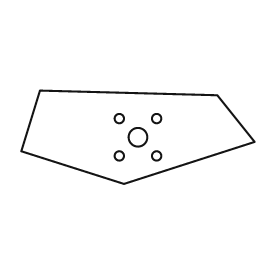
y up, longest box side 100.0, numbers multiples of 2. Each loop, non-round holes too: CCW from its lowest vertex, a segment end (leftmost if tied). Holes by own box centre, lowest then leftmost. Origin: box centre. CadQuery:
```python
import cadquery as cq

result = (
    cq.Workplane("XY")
    .moveTo(-6.0, -20.0)
    .lineTo(50.0, -2.0)
    .lineTo(34.0, 18.0)
    .lineTo(-42.0, 20.0)
    .lineTo(-50.0, -6.0)
    .close()
    .moveTo(-8.0, -8.0)
    .circle(2.0)
    .moveTo(8.0, -8.0)
    .circle(2.0)
    .moveTo(0.0, 0.0)
    .circle(4.0)
    .moveTo(-8.0, 8.0)
    .circle(2.0)
    .moveTo(8.0, 8.0)
    .circle(2.0)
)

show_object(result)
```